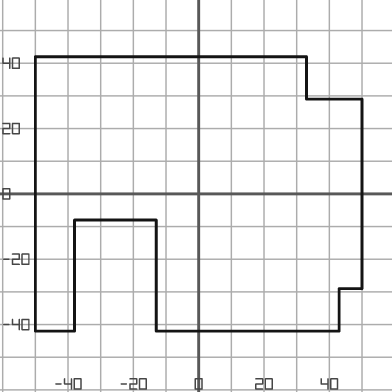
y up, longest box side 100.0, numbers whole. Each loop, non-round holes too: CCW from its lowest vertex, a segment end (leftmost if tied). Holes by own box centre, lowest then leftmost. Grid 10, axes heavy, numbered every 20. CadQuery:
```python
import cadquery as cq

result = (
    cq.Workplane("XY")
    .moveTo(-50.0, -42.0)
    .lineTo(-38.0, -42.0)
    .lineTo(-38.0, -8.0)
    .lineTo(-13.0, -8.0)
    .lineTo(-13.0, -42.0)
    .lineTo(43.0, -42.0)
    .lineTo(43.0, -29.0)
    .lineTo(50.0, -29.0)
    .lineTo(50.0, 29.0)
    .lineTo(33.0, 29.0)
    .lineTo(33.0, 42.0)
    .lineTo(-50.0, 42.0)
    .close()
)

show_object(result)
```